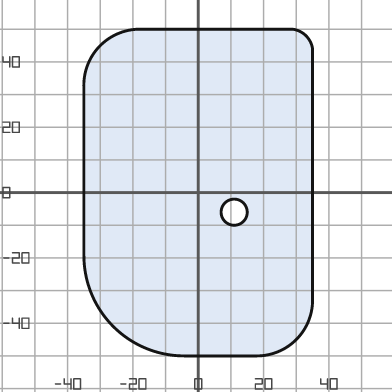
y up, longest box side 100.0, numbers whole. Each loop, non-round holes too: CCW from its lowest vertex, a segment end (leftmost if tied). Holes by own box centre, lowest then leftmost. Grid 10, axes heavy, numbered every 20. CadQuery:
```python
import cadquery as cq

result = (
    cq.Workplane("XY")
    .moveTo(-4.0, -50.0)
    .lineTo(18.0, -50.0)
    .threePointArc((30.0, -45.0), (35.0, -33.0))
    .lineTo(35.0, 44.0)
    .threePointArc((33.0, 48.0), (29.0, 50.0))
    .lineTo(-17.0, 50.0)
    .threePointArc((-30.0, 45.0), (-35.0, 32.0))
    .lineTo(-35.0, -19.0)
    .threePointArc((-26.0, -41.0), (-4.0, -50.0))
    .close()
    .moveTo(11.0, -6.0)
    .circle(4.0)
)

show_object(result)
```